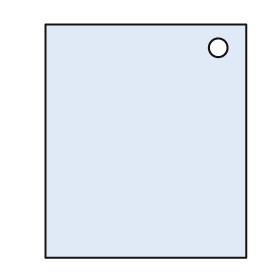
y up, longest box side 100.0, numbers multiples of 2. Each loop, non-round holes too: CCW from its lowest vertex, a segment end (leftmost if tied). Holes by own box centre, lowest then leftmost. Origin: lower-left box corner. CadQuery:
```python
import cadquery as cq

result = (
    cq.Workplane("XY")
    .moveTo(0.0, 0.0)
    .lineTo(86.0, 0.0)
    .lineTo(86.0, 100.0)
    .lineTo(0.0, 100.0)
    .close()
    .moveTo(74.0, 90.0)
    .circle(4.0)
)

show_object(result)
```